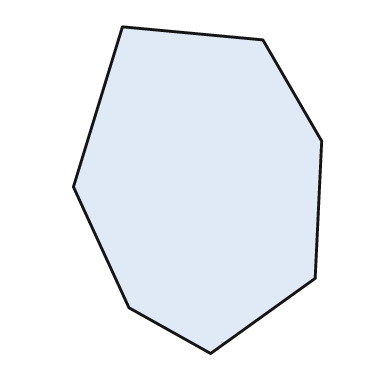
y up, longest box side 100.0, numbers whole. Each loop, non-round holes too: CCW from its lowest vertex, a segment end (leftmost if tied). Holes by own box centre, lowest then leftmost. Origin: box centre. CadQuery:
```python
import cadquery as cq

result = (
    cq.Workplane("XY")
    .moveTo(4.0, -50.0)
    .lineTo(36.0, -27.0)
    .lineTo(38.0, 15.0)
    .lineTo(20.0, 46.0)
    .lineTo(-23.0, 50.0)
    .lineTo(-38.0, 1.0)
    .lineTo(-21.0, -36.0)
    .close()
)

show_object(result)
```